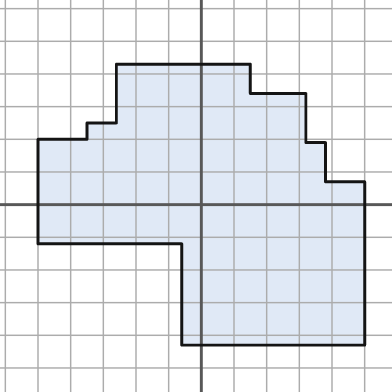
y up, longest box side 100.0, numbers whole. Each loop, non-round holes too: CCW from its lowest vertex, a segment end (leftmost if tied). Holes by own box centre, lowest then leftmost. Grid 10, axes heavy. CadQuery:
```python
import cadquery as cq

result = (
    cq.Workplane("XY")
    .moveTo(-6.0, -43.0)
    .lineTo(50.0, -43.0)
    .lineTo(50.0, 7.0)
    .lineTo(38.0, 7.0)
    .lineTo(38.0, 19.0)
    .lineTo(32.0, 19.0)
    .lineTo(32.0, 34.0)
    .lineTo(15.0, 34.0)
    .lineTo(15.0, 43.0)
    .lineTo(-26.0, 43.0)
    .lineTo(-26.0, 25.0)
    .lineTo(-35.0, 25.0)
    .lineTo(-35.0, 20.0)
    .lineTo(-50.0, 20.0)
    .lineTo(-50.0, -12.0)
    .lineTo(-6.0, -12.0)
    .close()
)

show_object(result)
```